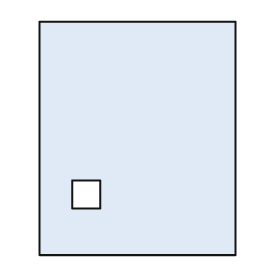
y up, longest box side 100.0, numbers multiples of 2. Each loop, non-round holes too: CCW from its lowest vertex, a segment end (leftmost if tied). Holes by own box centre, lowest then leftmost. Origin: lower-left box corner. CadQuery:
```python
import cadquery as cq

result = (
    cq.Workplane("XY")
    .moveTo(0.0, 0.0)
    .lineTo(84.0, 0.0)
    .lineTo(84.0, 100.0)
    .lineTo(0.0, 100.0)
    .close()
    .moveTo(14.0, 20.0)
    .lineTo(26.0, 20.0)
    .lineTo(26.0, 32.0)
    .lineTo(14.0, 32.0)
    .close()
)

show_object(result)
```